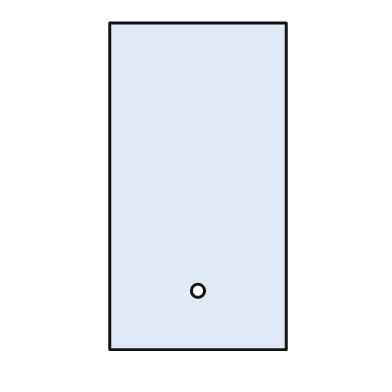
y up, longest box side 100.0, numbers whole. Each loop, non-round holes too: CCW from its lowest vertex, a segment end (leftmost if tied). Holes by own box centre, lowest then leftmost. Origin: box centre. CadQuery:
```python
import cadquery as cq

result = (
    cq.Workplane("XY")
    .moveTo(-27.0, -50.0)
    .lineTo(27.0, -50.0)
    .lineTo(27.0, 50.0)
    .lineTo(-27.0, 50.0)
    .close()
    .moveTo(0.0, -32.0)
    .circle(2.0)
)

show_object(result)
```